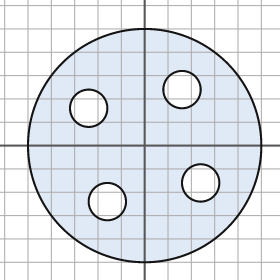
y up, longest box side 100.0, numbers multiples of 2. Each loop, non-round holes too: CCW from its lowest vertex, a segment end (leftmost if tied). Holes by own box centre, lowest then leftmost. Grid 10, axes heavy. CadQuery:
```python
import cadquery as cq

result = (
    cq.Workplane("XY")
    .moveTo(0.0, 0.0)
    .circle(50.0)
    .moveTo(-16.0, -24.0)
    .circle(8.0)
    .moveTo(24.0, -16.0)
    .circle(8.0)
    .moveTo(-24.0, 16.0)
    .circle(8.0)
    .moveTo(16.0, 24.0)
    .circle(8.0)
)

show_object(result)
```